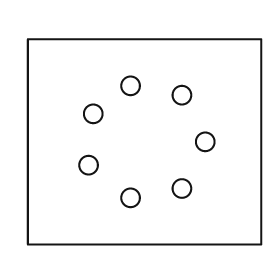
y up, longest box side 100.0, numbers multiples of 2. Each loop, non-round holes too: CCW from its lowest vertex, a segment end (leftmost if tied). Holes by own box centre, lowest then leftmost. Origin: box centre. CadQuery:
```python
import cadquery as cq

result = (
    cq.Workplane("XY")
    .moveTo(-50.0, -44.0)
    .lineTo(50.0, -44.0)
    .lineTo(50.0, 44.0)
    .lineTo(-50.0, 44.0)
    .close()
    .moveTo(-6.0, -24.0)
    .circle(4.0)
    .moveTo(16.0, -20.0)
    .circle(4.0)
    .moveTo(-24.0, -10.0)
    .circle(4.0)
    .moveTo(26.0, 0.0)
    .circle(4.0)
    .moveTo(-22.0, 12.0)
    .circle(4.0)
    .moveTo(16.0, 20.0)
    .circle(4.0)
    .moveTo(-6.0, 24.0)
    .circle(4.0)
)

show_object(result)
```